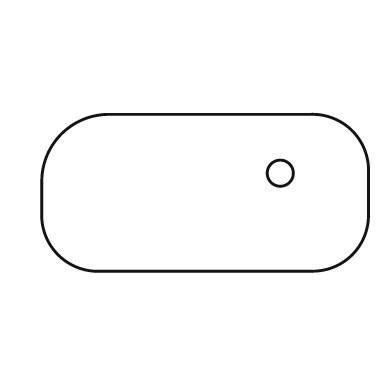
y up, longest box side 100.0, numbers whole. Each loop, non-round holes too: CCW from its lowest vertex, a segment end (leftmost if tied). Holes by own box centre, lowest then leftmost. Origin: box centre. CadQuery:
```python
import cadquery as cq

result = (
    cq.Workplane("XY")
    .moveTo(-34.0, -24.0)
    .lineTo(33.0, -24.0)
    .threePointArc((45.0, -19.0), (50.0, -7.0))
    .lineTo(50.0, 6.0)
    .threePointArc((45.0, 19.0), (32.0, 24.0))
    .lineTo(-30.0, 24.0)
    .threePointArc((-44.0, 18.0), (-50.0, 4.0))
    .lineTo(-50.0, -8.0)
    .threePointArc((-45.0, -19.0), (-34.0, -24.0))
    .close()
    .moveTo(23.0, 6.0)
    .circle(4.0)
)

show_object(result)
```